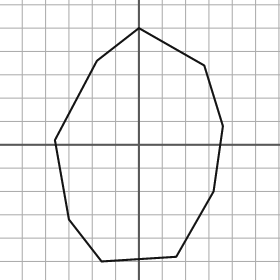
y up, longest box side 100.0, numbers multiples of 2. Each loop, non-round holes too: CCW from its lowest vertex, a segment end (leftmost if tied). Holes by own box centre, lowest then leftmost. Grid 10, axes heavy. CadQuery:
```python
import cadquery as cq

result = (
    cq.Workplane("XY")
    .moveTo(-16.0, -50.0)
    .lineTo(16.0, -48.0)
    .lineTo(32.0, -20.0)
    .lineTo(36.0, 8.0)
    .lineTo(28.0, 34.0)
    .lineTo(0.0, 50.0)
    .lineTo(-18.0, 36.0)
    .lineTo(-36.0, 2.0)
    .lineTo(-30.0, -32.0)
    .close()
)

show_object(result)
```